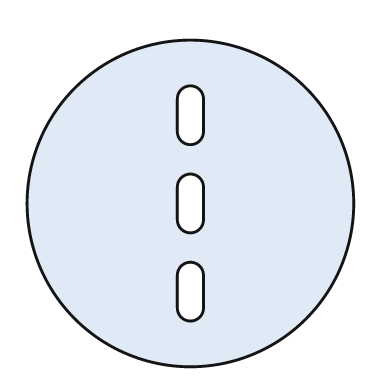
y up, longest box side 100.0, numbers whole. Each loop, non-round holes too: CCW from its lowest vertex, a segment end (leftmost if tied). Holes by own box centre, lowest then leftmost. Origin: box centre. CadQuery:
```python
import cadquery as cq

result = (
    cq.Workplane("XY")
    .moveTo(0.0, 0.0)
    .circle(50.0)
    .moveTo(-4.0, -32.0)
    .threePointArc((0.0, -36.0), (4.0, -32.0))
    .lineTo(4.0, -22.0)
    .threePointArc((0.0, -18.0), (-4.0, -22.0))
    .close()
    .moveTo(-4.0, -5.0)
    .threePointArc((0.0, -9.0), (4.0, -5.0))
    .lineTo(4.0, 5.0)
    .threePointArc((0.0, 9.0), (-4.0, 5.0))
    .close()
    .moveTo(-4.0, 22.0)
    .threePointArc((0.0, 18.0), (4.0, 22.0))
    .lineTo(4.0, 32.0)
    .threePointArc((0.0, 36.0), (-4.0, 32.0))
    .close()
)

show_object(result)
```